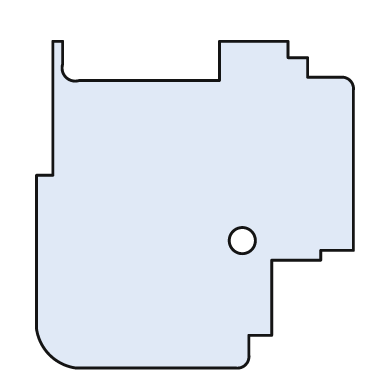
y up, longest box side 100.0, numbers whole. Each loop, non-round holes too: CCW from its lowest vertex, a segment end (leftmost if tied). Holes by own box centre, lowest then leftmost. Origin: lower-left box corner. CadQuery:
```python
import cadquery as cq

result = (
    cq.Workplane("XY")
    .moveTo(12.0, 0.0)
    .lineTo(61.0, 0.0)
    .threePointArc((64.0, 1.0), (65.0, 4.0))
    .lineTo(65.0, 10.0)
    .lineTo(72.0, 10.0)
    .lineTo(72.0, 33.0)
    .lineTo(87.0, 33.0)
    .lineTo(87.0, 36.0)
    .lineTo(97.0, 36.0)
    .lineTo(97.0, 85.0)
    .threePointArc((96.0, 88.0), (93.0, 89.0))
    .lineTo(83.0, 89.0)
    .lineTo(83.0, 95.0)
    .lineTo(77.0, 95.0)
    .lineTo(77.0, 100.0)
    .lineTo(56.0, 100.0)
    .lineTo(56.0, 88.0)
    .lineTo(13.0, 88.0)
    .threePointArc((9.0, 89.0), (8.0, 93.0))
    .lineTo(8.0, 100.0)
    .lineTo(5.0, 100.0)
    .lineTo(5.0, 59.0)
    .lineTo(0.0, 59.0)
    .lineTo(0.0, 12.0)
    .threePointArc((4.0, 4.0), (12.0, 0.0))
    .close()
    .moveTo(63.0, 39.0)
    .circle(4.0)
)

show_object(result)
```